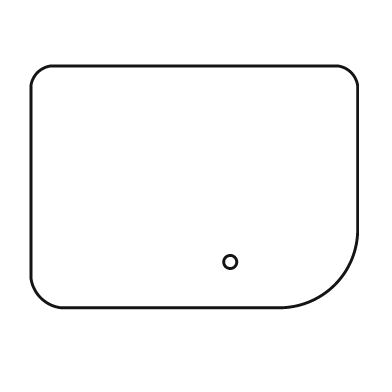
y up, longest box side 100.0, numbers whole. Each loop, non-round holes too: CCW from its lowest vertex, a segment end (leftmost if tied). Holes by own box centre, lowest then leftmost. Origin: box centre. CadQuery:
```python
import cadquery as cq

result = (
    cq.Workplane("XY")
    .moveTo(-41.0, -37.0)
    .lineTo(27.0, -37.0)
    .threePointArc((43.0, -30.0), (50.0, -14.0))
    .lineTo(50.0, 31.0)
    .threePointArc((48.0, 35.0), (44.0, 37.0))
    .lineTo(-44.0, 37.0)
    .threePointArc((-48.0, 35.0), (-50.0, 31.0))
    .lineTo(-50.0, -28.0)
    .threePointArc((-47.0, -34.0), (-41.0, -37.0))
    .close()
    .moveTo(11.0, -23.0)
    .circle(2.0)
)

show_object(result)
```